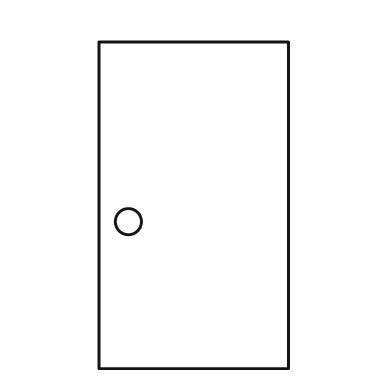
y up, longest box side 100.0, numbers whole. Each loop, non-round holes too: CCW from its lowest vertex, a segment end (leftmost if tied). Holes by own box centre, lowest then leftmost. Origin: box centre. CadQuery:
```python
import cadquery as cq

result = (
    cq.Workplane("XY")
    .moveTo(-29.0, -50.0)
    .lineTo(29.0, -50.0)
    .lineTo(29.0, 50.0)
    .lineTo(-29.0, 50.0)
    .close()
    .moveTo(-20.0, -5.0)
    .circle(4.0)
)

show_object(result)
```